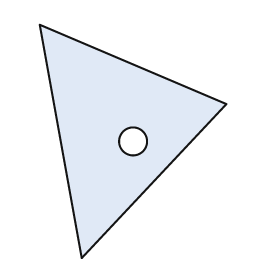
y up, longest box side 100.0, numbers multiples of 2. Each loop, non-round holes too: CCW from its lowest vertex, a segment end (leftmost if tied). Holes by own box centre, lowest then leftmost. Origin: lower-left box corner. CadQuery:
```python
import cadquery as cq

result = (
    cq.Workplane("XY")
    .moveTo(18.0, 0.0)
    .lineTo(80.0, 66.0)
    .lineTo(0.0, 100.0)
    .close()
    .moveTo(40.0, 50.0)
    .circle(6.0)
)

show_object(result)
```